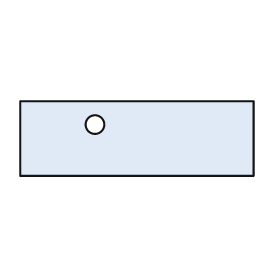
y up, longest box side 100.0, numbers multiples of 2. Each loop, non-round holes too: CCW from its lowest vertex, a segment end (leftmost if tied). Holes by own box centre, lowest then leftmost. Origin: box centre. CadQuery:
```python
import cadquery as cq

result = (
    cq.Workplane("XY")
    .moveTo(-50.0, -16.0)
    .lineTo(50.0, -16.0)
    .lineTo(50.0, 16.0)
    .lineTo(-50.0, 16.0)
    .close()
    .moveTo(-18.0, 6.0)
    .circle(4.0)
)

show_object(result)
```